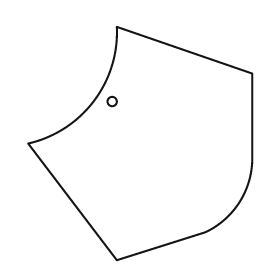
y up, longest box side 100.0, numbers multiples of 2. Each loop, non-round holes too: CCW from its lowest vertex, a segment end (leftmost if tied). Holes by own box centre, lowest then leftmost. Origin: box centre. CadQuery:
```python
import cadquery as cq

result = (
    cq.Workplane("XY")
    .moveTo(-10.0, -50.0)
    .lineTo(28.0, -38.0)
    .threePointArc((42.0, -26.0), (48.0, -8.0))
    .lineTo(48.0, 30.0)
    .lineTo(-10.0, 50.0)
    .threePointArc((-20.0, 18.0), (-48.0, 0.0))
    .close()
    .moveTo(-12.0, 18.0)
    .circle(2.0)
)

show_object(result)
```